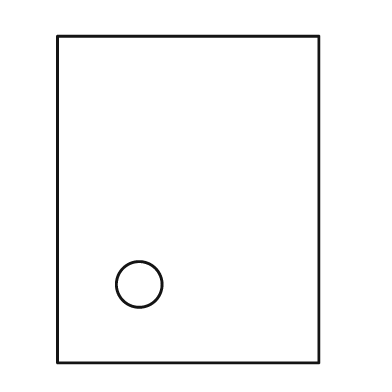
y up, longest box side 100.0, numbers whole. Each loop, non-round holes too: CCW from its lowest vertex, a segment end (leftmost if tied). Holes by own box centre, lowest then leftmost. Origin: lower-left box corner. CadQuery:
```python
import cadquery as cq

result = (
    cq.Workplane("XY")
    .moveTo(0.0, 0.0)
    .lineTo(80.0, 0.0)
    .lineTo(80.0, 100.0)
    .lineTo(0.0, 100.0)
    .close()
    .moveTo(25.0, 24.0)
    .circle(7.0)
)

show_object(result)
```